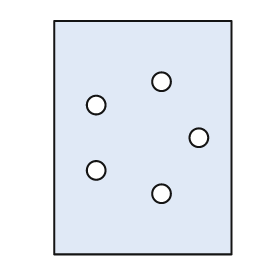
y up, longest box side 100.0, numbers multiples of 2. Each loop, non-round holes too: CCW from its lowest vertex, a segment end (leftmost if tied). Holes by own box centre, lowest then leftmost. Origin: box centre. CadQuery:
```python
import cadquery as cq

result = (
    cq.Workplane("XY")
    .moveTo(-38.0, -50.0)
    .lineTo(38.0, -50.0)
    .lineTo(38.0, 50.0)
    .lineTo(-38.0, 50.0)
    .close()
    .moveTo(8.0, -24.0)
    .circle(4.0)
    .moveTo(-20.0, -14.0)
    .circle(4.0)
    .moveTo(24.0, 0.0)
    .circle(4.0)
    .moveTo(-20.0, 14.0)
    .circle(4.0)
    .moveTo(8.0, 24.0)
    .circle(4.0)
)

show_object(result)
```